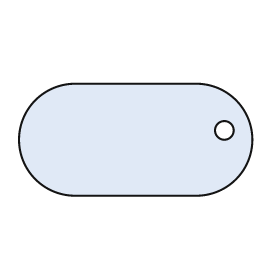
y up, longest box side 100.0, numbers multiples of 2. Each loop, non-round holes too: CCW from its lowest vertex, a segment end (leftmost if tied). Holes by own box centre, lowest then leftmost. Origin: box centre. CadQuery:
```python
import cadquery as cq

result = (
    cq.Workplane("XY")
    .moveTo(-26.0, -24.0)
    .lineTo(26.0, -24.0)
    .threePointArc((50.0, 0.0), (26.0, 24.0))
    .lineTo(-26.0, 24.0)
    .threePointArc((-50.0, 0.0), (-26.0, -24.0))
    .close()
    .moveTo(38.0, 4.0)
    .circle(4.0)
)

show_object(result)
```